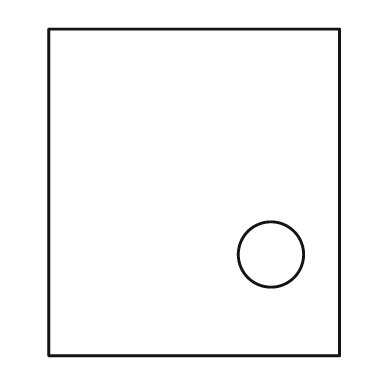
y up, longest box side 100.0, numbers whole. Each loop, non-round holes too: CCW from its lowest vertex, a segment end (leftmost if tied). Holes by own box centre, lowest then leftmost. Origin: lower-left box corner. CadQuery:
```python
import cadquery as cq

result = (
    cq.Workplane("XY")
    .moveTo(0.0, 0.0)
    .lineTo(89.0, 0.0)
    .lineTo(89.0, 100.0)
    .lineTo(0.0, 100.0)
    .close()
    .moveTo(68.0, 31.0)
    .circle(10.0)
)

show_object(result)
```